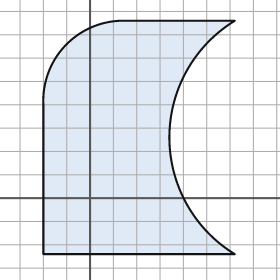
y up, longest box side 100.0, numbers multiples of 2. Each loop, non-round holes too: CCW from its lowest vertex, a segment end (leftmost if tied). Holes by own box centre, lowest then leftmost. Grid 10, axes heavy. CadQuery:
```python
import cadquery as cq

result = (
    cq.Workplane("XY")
    .moveTo(-20.0, -24.0)
    .lineTo(62.0, -24.0)
    .threePointArc((34.0, 26.0), (62.0, 76.0))
    .lineTo(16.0, 76.0)
    .threePointArc((-10.0, 66.0), (-20.0, 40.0))
    .close()
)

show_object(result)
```